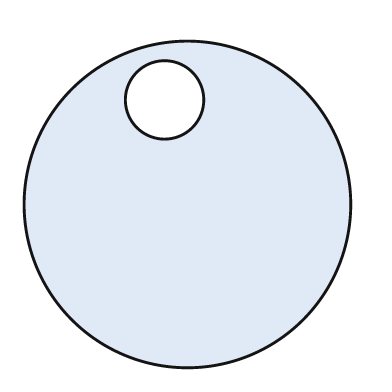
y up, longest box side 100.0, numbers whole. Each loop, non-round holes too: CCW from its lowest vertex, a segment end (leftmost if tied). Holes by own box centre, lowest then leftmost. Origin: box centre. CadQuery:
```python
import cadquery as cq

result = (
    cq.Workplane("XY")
    .moveTo(0.0, 0.0)
    .circle(50.0)
    .moveTo(-7.0, 32.0)
    .circle(12.0)
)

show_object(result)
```